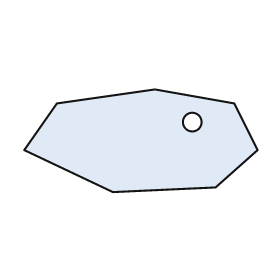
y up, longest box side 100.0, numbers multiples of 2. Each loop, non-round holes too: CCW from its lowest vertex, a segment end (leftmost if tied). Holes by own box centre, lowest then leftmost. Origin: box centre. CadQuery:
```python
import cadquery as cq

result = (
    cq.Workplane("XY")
    .moveTo(-12.0, -22.0)
    .lineTo(32.0, -20.0)
    .lineTo(50.0, -4.0)
    .lineTo(40.0, 16.0)
    .lineTo(6.0, 22.0)
    .lineTo(-36.0, 16.0)
    .lineTo(-50.0, -4.0)
    .close()
    .moveTo(22.0, 8.0)
    .circle(4.0)
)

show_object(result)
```